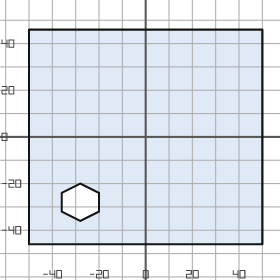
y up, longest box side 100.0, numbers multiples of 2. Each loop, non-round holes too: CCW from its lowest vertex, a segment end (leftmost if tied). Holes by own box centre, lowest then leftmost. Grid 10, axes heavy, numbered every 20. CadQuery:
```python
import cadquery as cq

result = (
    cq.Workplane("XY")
    .moveTo(-50.0, -46.0)
    .lineTo(50.0, -46.0)
    .lineTo(50.0, 46.0)
    .lineTo(-50.0, 46.0)
    .close()
    .moveTo(-28.0, -36.0)
    .lineTo(-20.0, -32.0)
    .lineTo(-20.0, -24.0)
    .lineTo(-28.0, -20.0)
    .lineTo(-36.0, -24.0)
    .lineTo(-36.0, -32.0)
    .close()
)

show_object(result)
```